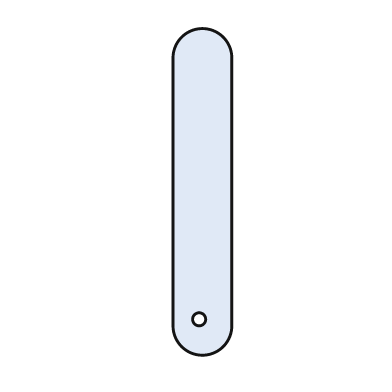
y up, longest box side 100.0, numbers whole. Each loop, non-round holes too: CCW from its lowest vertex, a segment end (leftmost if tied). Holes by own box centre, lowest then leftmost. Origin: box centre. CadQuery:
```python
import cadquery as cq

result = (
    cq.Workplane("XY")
    .moveTo(-9.0, -41.0)
    .threePointArc((0.0, -50.0), (9.0, -41.0))
    .lineTo(9.0, 41.0)
    .threePointArc((0.0, 50.0), (-9.0, 41.0))
    .close()
    .moveTo(-1.0, -39.0)
    .circle(2.0)
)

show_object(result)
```